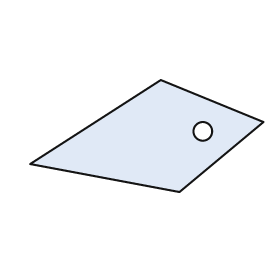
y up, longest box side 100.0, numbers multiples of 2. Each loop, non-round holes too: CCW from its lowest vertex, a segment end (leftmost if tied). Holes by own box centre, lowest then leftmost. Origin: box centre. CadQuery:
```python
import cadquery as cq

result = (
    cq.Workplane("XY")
    .moveTo(14.0, -24.0)
    .lineTo(50.0, 6.0)
    .lineTo(6.0, 24.0)
    .lineTo(-50.0, -12.0)
    .close()
    .moveTo(24.0, 2.0)
    .circle(4.0)
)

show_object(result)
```